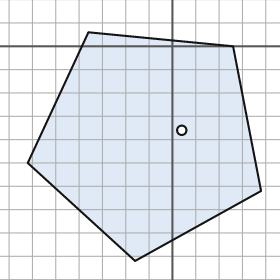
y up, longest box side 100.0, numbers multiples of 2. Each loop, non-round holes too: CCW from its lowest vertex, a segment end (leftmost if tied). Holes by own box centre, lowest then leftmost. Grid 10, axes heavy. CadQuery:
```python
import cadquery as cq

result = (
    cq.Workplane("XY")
    .moveTo(-16.0, -92.0)
    .lineTo(38.0, -62.0)
    .lineTo(26.0, 0.0)
    .lineTo(-36.0, 6.0)
    .lineTo(-62.0, -50.0)
    .close()
    .moveTo(4.0, -36.0)
    .circle(2.0)
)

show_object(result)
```